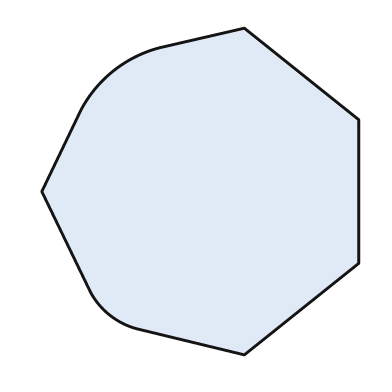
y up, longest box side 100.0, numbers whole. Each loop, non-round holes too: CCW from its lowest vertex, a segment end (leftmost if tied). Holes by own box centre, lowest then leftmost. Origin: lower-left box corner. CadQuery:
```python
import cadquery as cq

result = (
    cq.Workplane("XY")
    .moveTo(62.0, 0.0)
    .lineTo(97.0, 28.0)
    .lineTo(97.0, 72.0)
    .lineTo(62.0, 100.0)
    .lineTo(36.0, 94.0)
    .threePointArc((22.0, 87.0), (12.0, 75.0))
    .lineTo(0.0, 50.0)
    .lineTo(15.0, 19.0)
    .threePointArc((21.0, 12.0), (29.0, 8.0))
    .close()
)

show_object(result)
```